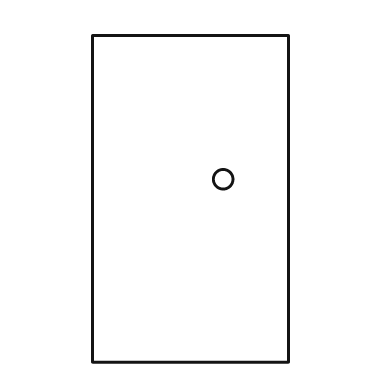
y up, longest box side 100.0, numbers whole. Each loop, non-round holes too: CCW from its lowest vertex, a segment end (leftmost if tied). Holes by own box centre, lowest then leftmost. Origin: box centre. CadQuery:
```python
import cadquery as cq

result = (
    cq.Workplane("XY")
    .moveTo(-30.0, -50.0)
    .lineTo(30.0, -50.0)
    .lineTo(30.0, 50.0)
    .lineTo(-30.0, 50.0)
    .close()
    .moveTo(10.0, 6.0)
    .circle(3.0)
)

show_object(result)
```